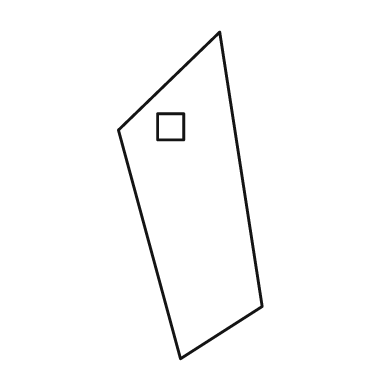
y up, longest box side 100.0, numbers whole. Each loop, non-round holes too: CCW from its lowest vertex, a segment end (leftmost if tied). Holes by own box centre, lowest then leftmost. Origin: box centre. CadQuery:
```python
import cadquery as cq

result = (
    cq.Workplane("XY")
    .moveTo(-3.0, -50.0)
    .lineTo(22.0, -34.0)
    .lineTo(9.0, 50.0)
    .lineTo(-22.0, 20.0)
    .close()
    .moveTo(-10.0, 17.0)
    .lineTo(-2.0, 17.0)
    .lineTo(-2.0, 25.0)
    .lineTo(-10.0, 25.0)
    .close()
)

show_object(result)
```